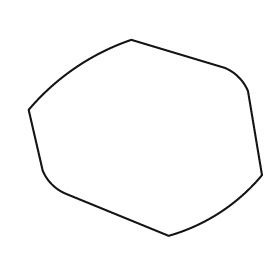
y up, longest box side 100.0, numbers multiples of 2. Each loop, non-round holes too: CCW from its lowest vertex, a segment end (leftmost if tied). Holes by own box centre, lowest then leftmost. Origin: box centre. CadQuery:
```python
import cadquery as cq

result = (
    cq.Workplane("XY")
    .moveTo(10.0, -42.0)
    .threePointArc((32.0, -32.0), (50.0, -16.0))
    .lineTo(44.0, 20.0)
    .threePointArc((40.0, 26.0), (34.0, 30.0))
    .lineTo(-6.0, 42.0)
    .threePointArc((-30.0, 30.0), (-50.0, 12.0))
    .lineTo(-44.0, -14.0)
    .threePointArc((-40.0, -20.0), (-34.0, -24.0))
    .close()
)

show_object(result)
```